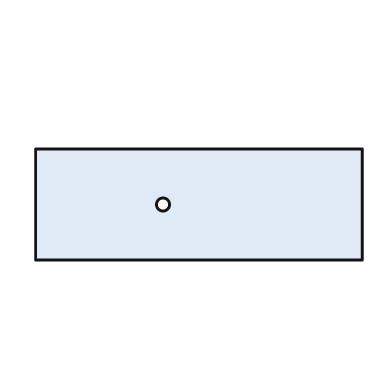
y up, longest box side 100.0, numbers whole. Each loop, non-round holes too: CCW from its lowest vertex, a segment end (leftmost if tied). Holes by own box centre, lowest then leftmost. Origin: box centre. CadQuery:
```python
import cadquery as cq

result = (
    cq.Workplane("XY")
    .moveTo(-50.0, -17.0)
    .lineTo(50.0, -17.0)
    .lineTo(50.0, 17.0)
    .lineTo(-50.0, 17.0)
    .close()
    .moveTo(-11.0, 0.0)
    .circle(2.0)
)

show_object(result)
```